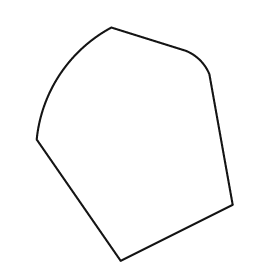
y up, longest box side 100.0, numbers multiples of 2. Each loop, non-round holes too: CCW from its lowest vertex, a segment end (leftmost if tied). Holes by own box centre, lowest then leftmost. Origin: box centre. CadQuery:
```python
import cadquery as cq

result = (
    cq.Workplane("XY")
    .moveTo(-6.0, -50.0)
    .lineTo(42.0, -26.0)
    .lineTo(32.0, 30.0)
    .threePointArc((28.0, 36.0), (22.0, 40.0))
    .lineTo(-10.0, 50.0)
    .threePointArc((-32.0, 30.0), (-42.0, 2.0))
    .close()
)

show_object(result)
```